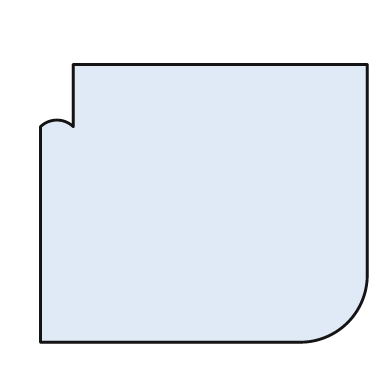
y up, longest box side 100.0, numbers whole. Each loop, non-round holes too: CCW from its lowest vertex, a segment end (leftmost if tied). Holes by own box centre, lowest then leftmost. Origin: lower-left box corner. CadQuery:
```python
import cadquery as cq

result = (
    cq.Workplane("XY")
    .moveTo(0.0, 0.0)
    .lineTo(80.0, 0.0)
    .threePointArc((94.0, 6.0), (100.0, 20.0))
    .lineTo(100.0, 85.0)
    .lineTo(10.0, 85.0)
    .lineTo(10.0, 66.0)
    .threePointArc((5.0, 68.0), (0.0, 66.0))
    .close()
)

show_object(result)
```